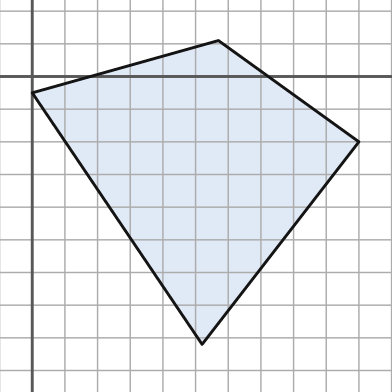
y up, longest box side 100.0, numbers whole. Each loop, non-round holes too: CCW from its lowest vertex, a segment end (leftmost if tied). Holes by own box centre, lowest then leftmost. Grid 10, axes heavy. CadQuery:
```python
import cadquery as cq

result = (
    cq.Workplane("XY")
    .moveTo(52.0, -82.0)
    .lineTo(100.0, -20.0)
    .lineTo(57.0, 11.0)
    .lineTo(0.0, -5.0)
    .close()
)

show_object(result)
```